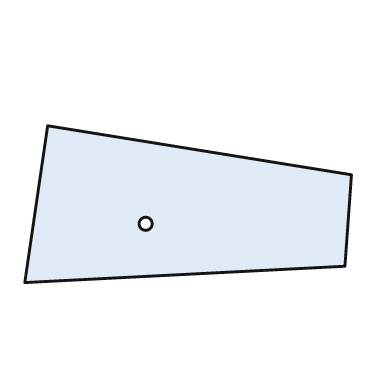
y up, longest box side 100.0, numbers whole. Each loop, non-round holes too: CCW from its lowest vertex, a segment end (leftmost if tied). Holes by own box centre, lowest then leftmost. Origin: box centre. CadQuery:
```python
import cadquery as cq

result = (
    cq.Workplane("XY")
    .moveTo(-50.0, -24.0)
    .lineTo(48.0, -19.0)
    .lineTo(50.0, 9.0)
    .lineTo(-43.0, 24.0)
    .close()
    .moveTo(-13.0, -6.0)
    .circle(2.0)
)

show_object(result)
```